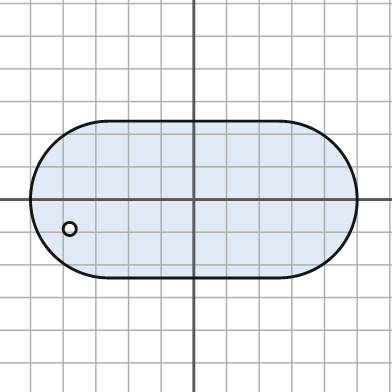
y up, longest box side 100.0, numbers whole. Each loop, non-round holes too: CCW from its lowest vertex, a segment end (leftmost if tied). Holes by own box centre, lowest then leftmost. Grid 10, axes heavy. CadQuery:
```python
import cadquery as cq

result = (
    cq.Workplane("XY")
    .moveTo(-26.0, -24.0)
    .lineTo(26.0, -24.0)
    .threePointArc((50.0, 0.0), (26.0, 24.0))
    .lineTo(-26.0, 24.0)
    .threePointArc((-50.0, 0.0), (-26.0, -24.0))
    .close()
    .moveTo(-38.0, -9.0)
    .circle(2.0)
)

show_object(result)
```